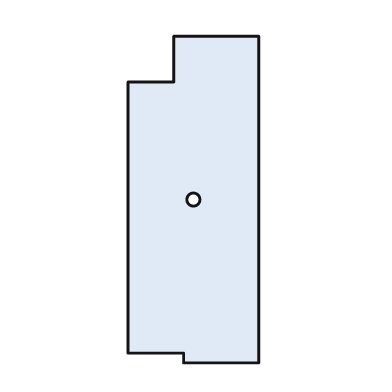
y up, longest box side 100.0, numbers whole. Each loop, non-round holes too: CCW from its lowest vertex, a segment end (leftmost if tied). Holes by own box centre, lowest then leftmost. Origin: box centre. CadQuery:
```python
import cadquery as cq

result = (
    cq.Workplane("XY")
    .moveTo(-3.0, -50.0)
    .lineTo(20.0, -50.0)
    .lineTo(20.0, 50.0)
    .lineTo(-6.0, 50.0)
    .lineTo(-6.0, 36.0)
    .lineTo(-20.0, 36.0)
    .lineTo(-20.0, -47.0)
    .lineTo(-3.0, -47.0)
    .close()
    .moveTo(0.0, 0.0)
    .circle(2.0)
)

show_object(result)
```